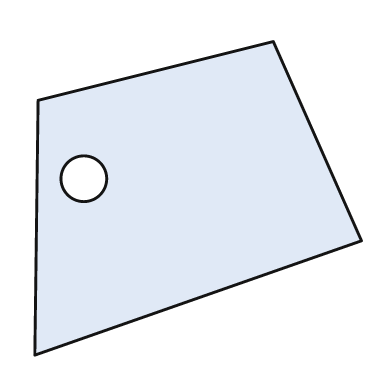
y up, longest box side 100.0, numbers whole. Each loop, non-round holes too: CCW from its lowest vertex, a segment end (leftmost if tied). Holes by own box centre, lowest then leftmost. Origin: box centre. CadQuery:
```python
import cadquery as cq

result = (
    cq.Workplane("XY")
    .moveTo(-50.0, -48.0)
    .lineTo(50.0, -13.0)
    .lineTo(23.0, 48.0)
    .lineTo(-49.0, 30.0)
    .close()
    .moveTo(-35.0, 6.0)
    .circle(7.0)
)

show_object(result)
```